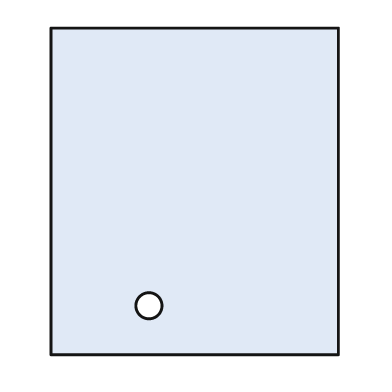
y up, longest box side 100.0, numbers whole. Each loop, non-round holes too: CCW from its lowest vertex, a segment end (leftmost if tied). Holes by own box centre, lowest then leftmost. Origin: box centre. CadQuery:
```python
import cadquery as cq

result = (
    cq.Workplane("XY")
    .moveTo(-44.0, -50.0)
    .lineTo(44.0, -50.0)
    .lineTo(44.0, 50.0)
    .lineTo(-44.0, 50.0)
    .close()
    .moveTo(-14.0, -35.0)
    .circle(4.0)
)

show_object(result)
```